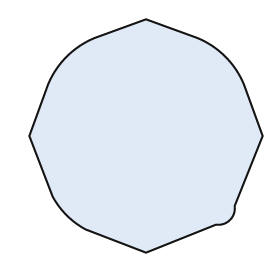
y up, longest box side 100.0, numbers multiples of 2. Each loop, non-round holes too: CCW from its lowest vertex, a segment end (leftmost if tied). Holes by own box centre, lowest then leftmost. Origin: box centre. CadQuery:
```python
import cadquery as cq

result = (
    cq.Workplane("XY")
    .moveTo(0.0, -50.0)
    .lineTo(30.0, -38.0)
    .threePointArc((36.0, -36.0), (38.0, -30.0))
    .lineTo(50.0, 0.0)
    .lineTo(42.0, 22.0)
    .threePointArc((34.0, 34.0), (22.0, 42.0))
    .lineTo(0.0, 50.0)
    .lineTo(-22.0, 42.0)
    .threePointArc((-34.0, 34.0), (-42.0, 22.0))
    .lineTo(-50.0, 0.0)
    .lineTo(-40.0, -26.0)
    .threePointArc((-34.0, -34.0), (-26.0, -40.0))
    .close()
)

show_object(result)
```